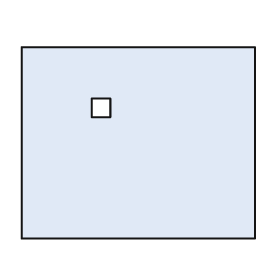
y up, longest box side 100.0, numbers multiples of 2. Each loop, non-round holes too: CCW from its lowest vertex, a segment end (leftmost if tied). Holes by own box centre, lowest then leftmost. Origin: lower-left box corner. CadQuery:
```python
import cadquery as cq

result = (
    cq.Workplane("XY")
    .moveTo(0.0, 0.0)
    .lineTo(100.0, 0.0)
    .lineTo(100.0, 82.0)
    .lineTo(0.0, 82.0)
    .close()
    .moveTo(30.0, 52.0)
    .lineTo(38.0, 52.0)
    .lineTo(38.0, 60.0)
    .lineTo(30.0, 60.0)
    .close()
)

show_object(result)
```